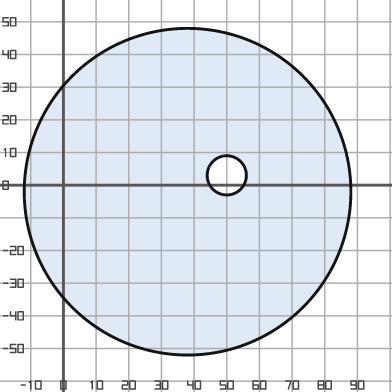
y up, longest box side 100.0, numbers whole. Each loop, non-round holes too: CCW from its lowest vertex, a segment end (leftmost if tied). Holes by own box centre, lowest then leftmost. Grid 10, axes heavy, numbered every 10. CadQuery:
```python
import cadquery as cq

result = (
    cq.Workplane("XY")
    .moveTo(38.0, -2.0)
    .circle(50.0)
    .moveTo(50.0, 3.0)
    .circle(6.0)
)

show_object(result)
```